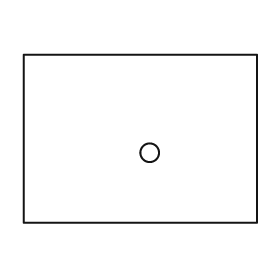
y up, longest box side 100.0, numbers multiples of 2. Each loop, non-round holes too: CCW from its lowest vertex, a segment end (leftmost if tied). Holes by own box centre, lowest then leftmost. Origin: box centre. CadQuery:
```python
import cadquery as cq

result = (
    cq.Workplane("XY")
    .moveTo(-50.0, -36.0)
    .lineTo(50.0, -36.0)
    .lineTo(50.0, 36.0)
    .lineTo(-50.0, 36.0)
    .close()
    .moveTo(4.0, -6.0)
    .circle(4.0)
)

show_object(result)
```